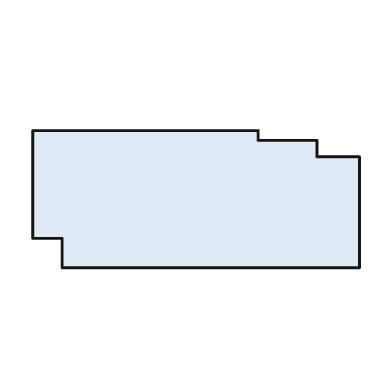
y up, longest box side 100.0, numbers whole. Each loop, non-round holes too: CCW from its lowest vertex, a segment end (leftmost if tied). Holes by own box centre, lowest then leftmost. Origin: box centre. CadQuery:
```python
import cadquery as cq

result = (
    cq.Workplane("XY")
    .moveTo(-41.0, -21.0)
    .lineTo(50.0, -21.0)
    .lineTo(50.0, 13.0)
    .lineTo(37.0, 13.0)
    .lineTo(37.0, 18.0)
    .lineTo(19.0, 18.0)
    .lineTo(19.0, 21.0)
    .lineTo(-50.0, 21.0)
    .lineTo(-50.0, -12.0)
    .lineTo(-41.0, -12.0)
    .close()
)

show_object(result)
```